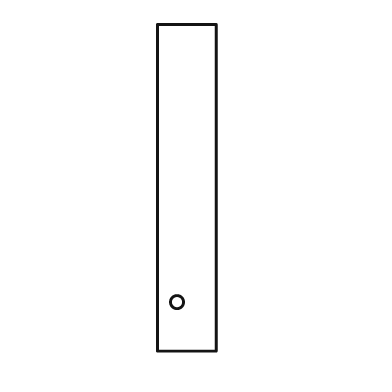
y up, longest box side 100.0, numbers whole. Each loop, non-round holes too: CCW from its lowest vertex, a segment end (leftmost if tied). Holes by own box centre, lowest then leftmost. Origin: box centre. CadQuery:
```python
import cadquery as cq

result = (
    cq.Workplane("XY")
    .moveTo(-9.0, -50.0)
    .lineTo(9.0, -50.0)
    .lineTo(9.0, 50.0)
    .lineTo(-9.0, 50.0)
    .close()
    .moveTo(-3.0, -35.0)
    .circle(2.0)
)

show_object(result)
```